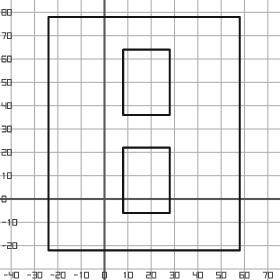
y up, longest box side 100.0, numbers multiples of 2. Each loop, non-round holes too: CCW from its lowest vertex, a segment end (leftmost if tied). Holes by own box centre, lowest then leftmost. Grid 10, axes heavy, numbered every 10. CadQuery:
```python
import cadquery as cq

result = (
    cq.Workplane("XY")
    .moveTo(-24.0, -22.0)
    .lineTo(58.0, -22.0)
    .lineTo(58.0, 78.0)
    .lineTo(-24.0, 78.0)
    .close()
    .moveTo(8.0, -6.0)
    .lineTo(28.0, -6.0)
    .lineTo(28.0, 22.0)
    .lineTo(8.0, 22.0)
    .close()
    .moveTo(8.0, 36.0)
    .lineTo(28.0, 36.0)
    .lineTo(28.0, 64.0)
    .lineTo(8.0, 64.0)
    .close()
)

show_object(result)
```